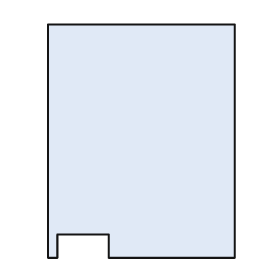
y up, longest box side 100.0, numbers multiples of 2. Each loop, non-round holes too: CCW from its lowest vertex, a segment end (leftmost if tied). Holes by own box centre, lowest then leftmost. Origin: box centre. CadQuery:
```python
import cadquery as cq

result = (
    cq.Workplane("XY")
    .moveTo(-40.0, -50.0)
    .lineTo(-36.0, -50.0)
    .lineTo(-36.0, -40.0)
    .lineTo(-14.0, -40.0)
    .lineTo(-14.0, -50.0)
    .lineTo(40.0, -50.0)
    .lineTo(40.0, 50.0)
    .lineTo(-40.0, 50.0)
    .close()
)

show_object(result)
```